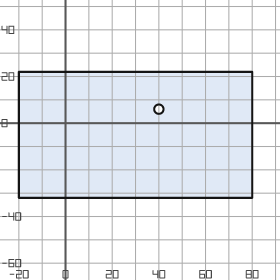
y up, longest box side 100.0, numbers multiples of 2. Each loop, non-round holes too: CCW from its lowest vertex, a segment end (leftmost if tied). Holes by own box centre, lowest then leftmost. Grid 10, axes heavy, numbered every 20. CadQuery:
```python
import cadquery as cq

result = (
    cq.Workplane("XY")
    .moveTo(-20.0, -32.0)
    .lineTo(80.0, -32.0)
    .lineTo(80.0, 22.0)
    .lineTo(-20.0, 22.0)
    .close()
    .moveTo(40.0, 6.0)
    .circle(2.0)
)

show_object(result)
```